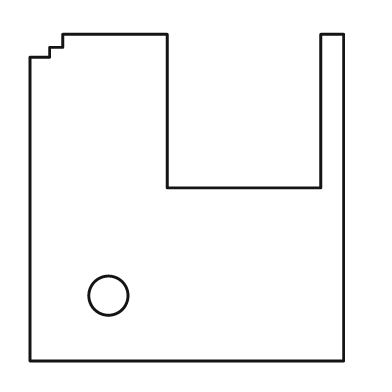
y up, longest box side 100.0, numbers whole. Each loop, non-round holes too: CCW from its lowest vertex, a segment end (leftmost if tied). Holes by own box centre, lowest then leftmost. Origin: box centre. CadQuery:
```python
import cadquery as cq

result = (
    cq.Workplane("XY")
    .moveTo(-48.0, -50.0)
    .lineTo(48.0, -50.0)
    .lineTo(48.0, 50.0)
    .lineTo(41.0, 50.0)
    .lineTo(41.0, 3.0)
    .lineTo(-6.0, 3.0)
    .lineTo(-6.0, 50.0)
    .lineTo(-38.0, 50.0)
    .lineTo(-38.0, 46.0)
    .lineTo(-42.0, 46.0)
    .lineTo(-42.0, 43.0)
    .lineTo(-48.0, 43.0)
    .close()
    .moveTo(-24.0, -30.0)
    .circle(6.0)
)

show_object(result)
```